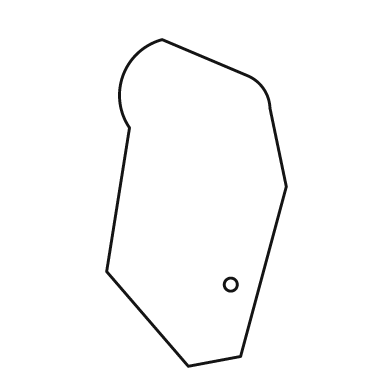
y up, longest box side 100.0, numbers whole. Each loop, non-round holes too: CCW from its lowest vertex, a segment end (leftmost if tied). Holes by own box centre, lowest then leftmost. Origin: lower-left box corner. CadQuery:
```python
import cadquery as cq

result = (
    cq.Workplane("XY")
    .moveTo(25.0, 0.0)
    .lineTo(41.0, 3.0)
    .lineTo(55.0, 55.0)
    .lineTo(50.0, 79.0)
    .threePointArc((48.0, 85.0), (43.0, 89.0))
    .lineTo(17.0, 100.0)
    .threePointArc((5.0, 89.0), (7.0, 73.0))
    .lineTo(0.0, 29.0)
    .close()
    .moveTo(38.0, 25.0)
    .circle(2.0)
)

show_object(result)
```